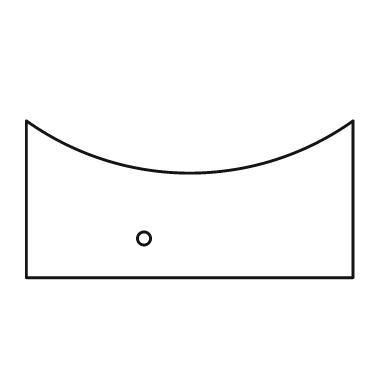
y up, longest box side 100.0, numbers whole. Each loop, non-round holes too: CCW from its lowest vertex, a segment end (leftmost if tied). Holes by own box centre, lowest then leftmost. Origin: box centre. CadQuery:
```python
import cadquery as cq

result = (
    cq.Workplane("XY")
    .moveTo(-50.0, -24.0)
    .lineTo(50.0, -24.0)
    .lineTo(50.0, 24.0)
    .threePointArc((0.0, 8.0), (-50.0, 24.0))
    .close()
    .moveTo(-14.0, -12.0)
    .circle(2.0)
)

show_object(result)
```